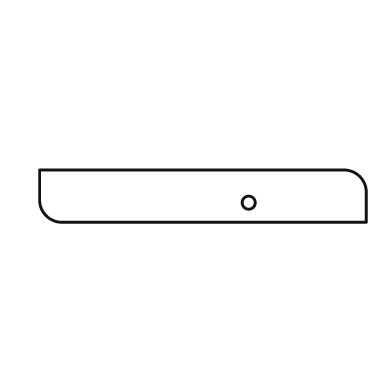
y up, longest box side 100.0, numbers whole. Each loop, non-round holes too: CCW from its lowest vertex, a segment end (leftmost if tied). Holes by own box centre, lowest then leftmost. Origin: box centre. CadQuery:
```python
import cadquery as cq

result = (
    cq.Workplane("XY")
    .moveTo(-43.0, -8.0)
    .lineTo(50.0, -8.0)
    .lineTo(50.0, 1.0)
    .threePointArc((48.0, 6.0), (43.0, 8.0))
    .lineTo(-50.0, 8.0)
    .lineTo(-50.0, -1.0)
    .threePointArc((-48.0, -6.0), (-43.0, -8.0))
    .close()
    .moveTo(14.0, -2.0)
    .circle(2.0)
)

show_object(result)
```